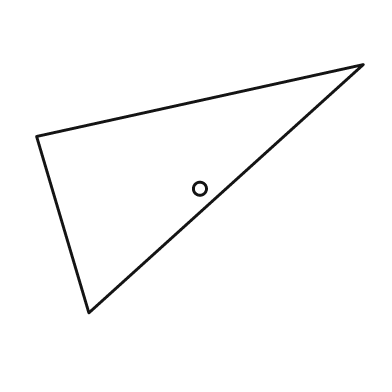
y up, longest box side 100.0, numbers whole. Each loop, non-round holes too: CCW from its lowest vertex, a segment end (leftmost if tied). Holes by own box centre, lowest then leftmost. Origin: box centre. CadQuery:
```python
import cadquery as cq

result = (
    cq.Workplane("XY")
    .moveTo(-34.0, -38.0)
    .lineTo(50.0, 38.0)
    .lineTo(-50.0, 16.0)
    .close()
    .moveTo(0.0, 0.0)
    .circle(2.0)
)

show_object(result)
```